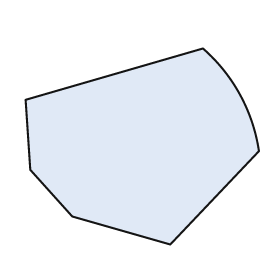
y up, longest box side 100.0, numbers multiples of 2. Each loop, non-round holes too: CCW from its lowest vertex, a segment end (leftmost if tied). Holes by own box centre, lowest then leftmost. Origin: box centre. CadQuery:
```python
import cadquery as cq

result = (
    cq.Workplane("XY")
    .moveTo(12.0, -42.0)
    .lineTo(50.0, -2.0)
    .threePointArc((42.0, 22.0), (26.0, 42.0))
    .lineTo(-50.0, 20.0)
    .lineTo(-48.0, -10.0)
    .lineTo(-30.0, -30.0)
    .close()
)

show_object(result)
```